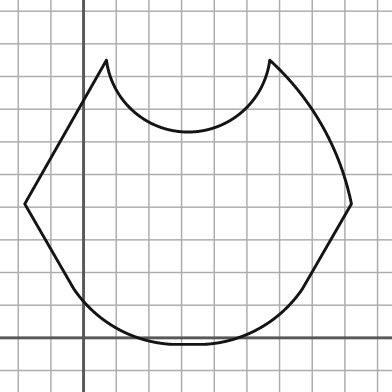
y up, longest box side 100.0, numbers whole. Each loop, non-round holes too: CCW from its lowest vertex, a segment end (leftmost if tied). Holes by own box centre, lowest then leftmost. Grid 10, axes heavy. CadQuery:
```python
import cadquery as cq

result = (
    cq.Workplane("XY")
    .moveTo(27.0, -2.0)
    .lineTo(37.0, -2.0)
    .threePointArc((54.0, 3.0), (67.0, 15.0))
    .lineTo(82.0, 41.0)
    .threePointArc((73.0, 65.0), (57.0, 85.0))
    .threePointArc((32.0, 63.0), (7.0, 85.0))
    .lineTo(-18.0, 41.0)
    .lineTo(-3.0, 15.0)
    .threePointArc((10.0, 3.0), (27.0, -2.0))
    .close()
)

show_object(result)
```